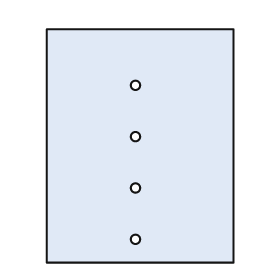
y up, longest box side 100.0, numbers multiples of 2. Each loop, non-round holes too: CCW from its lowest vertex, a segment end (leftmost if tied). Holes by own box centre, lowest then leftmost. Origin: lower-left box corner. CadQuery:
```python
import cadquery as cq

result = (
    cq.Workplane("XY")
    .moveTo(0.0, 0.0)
    .lineTo(80.0, 0.0)
    .lineTo(80.0, 100.0)
    .lineTo(0.0, 100.0)
    .close()
    .moveTo(38.0, 10.0)
    .circle(2.0)
    .moveTo(38.0, 32.0)
    .circle(2.0)
    .moveTo(38.0, 54.0)
    .circle(2.0)
    .moveTo(38.0, 76.0)
    .circle(2.0)
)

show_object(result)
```